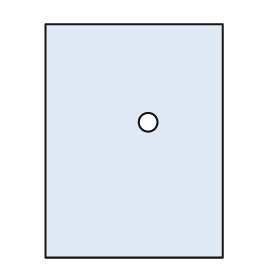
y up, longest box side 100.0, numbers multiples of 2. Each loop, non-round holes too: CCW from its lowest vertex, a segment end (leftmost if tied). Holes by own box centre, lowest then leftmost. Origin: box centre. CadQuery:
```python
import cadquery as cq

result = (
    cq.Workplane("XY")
    .moveTo(-38.0, -50.0)
    .lineTo(38.0, -50.0)
    .lineTo(38.0, 50.0)
    .lineTo(-38.0, 50.0)
    .close()
    .moveTo(6.0, 8.0)
    .circle(4.0)
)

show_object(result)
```